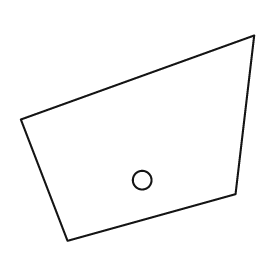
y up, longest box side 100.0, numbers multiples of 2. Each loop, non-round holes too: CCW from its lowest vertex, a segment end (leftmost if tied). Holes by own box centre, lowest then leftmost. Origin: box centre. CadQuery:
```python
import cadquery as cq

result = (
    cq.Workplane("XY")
    .moveTo(-30.0, -44.0)
    .lineTo(42.0, -24.0)
    .lineTo(50.0, 44.0)
    .lineTo(-50.0, 8.0)
    .close()
    .moveTo(2.0, -18.0)
    .circle(4.0)
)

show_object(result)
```